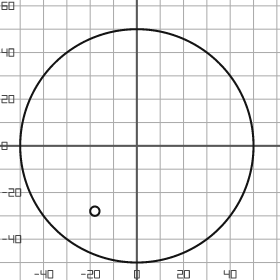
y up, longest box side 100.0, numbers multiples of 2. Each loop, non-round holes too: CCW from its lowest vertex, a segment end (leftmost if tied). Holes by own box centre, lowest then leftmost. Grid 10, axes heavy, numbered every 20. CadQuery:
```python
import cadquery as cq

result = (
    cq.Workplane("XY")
    .moveTo(0.0, 0.0)
    .circle(50.0)
    .moveTo(-18.0, -28.0)
    .circle(2.0)
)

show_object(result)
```